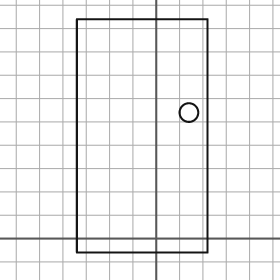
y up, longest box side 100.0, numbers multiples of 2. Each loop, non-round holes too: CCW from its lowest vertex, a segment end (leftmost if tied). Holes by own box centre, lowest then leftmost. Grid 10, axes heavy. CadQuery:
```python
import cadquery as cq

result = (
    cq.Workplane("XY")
    .moveTo(-34.0, -6.0)
    .lineTo(22.0, -6.0)
    .lineTo(22.0, 94.0)
    .lineTo(-34.0, 94.0)
    .close()
    .moveTo(14.0, 54.0)
    .circle(4.0)
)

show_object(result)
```